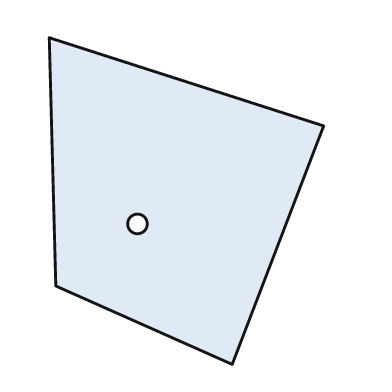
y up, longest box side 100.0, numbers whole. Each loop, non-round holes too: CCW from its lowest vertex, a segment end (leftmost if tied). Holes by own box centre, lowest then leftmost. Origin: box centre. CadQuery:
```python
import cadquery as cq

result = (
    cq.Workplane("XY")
    .moveTo(14.0, -50.0)
    .lineTo(42.0, 23.0)
    .lineTo(-42.0, 50.0)
    .lineTo(-40.0, -26.0)
    .close()
    .moveTo(-15.0, -7.0)
    .circle(3.0)
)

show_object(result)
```